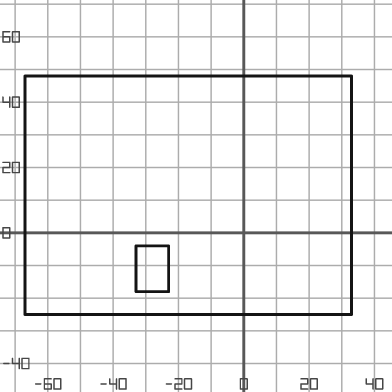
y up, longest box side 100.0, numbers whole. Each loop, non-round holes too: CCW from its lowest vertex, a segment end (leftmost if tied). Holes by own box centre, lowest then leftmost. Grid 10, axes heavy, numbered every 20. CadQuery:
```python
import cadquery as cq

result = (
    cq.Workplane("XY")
    .moveTo(-67.0, -25.0)
    .lineTo(33.0, -25.0)
    .lineTo(33.0, 48.0)
    .lineTo(-67.0, 48.0)
    .close()
    .moveTo(-33.0, -18.0)
    .lineTo(-23.0, -18.0)
    .lineTo(-23.0, -4.0)
    .lineTo(-33.0, -4.0)
    .close()
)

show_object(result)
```